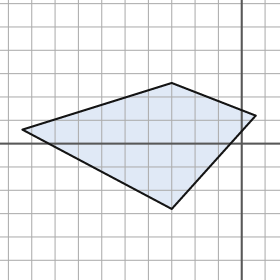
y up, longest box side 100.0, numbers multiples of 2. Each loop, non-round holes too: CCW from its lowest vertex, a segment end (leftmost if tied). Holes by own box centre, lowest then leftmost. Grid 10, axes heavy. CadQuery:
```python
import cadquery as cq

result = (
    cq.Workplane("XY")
    .moveTo(-30.0, -28.0)
    .lineTo(6.0, 12.0)
    .lineTo(-30.0, 26.0)
    .lineTo(-94.0, 6.0)
    .close()
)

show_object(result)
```